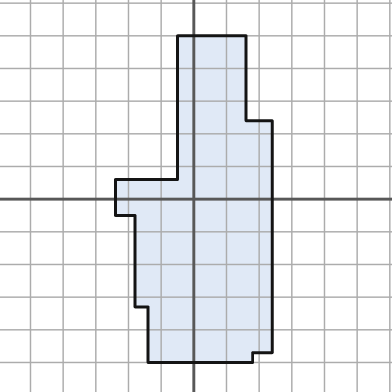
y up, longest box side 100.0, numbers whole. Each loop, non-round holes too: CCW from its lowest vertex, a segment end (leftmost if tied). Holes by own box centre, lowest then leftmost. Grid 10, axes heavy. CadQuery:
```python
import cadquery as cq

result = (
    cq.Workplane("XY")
    .moveTo(-14.0, -50.0)
    .lineTo(18.0, -50.0)
    .lineTo(18.0, -47.0)
    .lineTo(24.0, -47.0)
    .lineTo(24.0, 24.0)
    .lineTo(16.0, 24.0)
    .lineTo(16.0, 50.0)
    .lineTo(-5.0, 50.0)
    .lineTo(-5.0, 6.0)
    .lineTo(-24.0, 6.0)
    .lineTo(-24.0, -5.0)
    .lineTo(-18.0, -5.0)
    .lineTo(-18.0, -33.0)
    .lineTo(-14.0, -33.0)
    .close()
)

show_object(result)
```